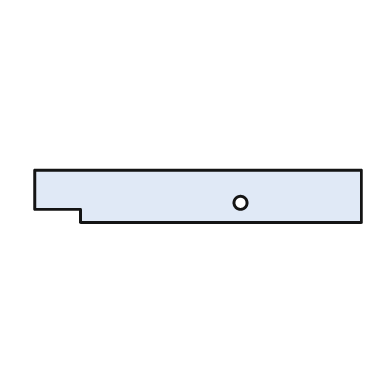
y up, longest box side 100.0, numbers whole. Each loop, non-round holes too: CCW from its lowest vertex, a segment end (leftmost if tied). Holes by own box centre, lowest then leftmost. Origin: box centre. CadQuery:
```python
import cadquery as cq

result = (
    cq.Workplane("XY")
    .moveTo(-36.0, -8.0)
    .lineTo(50.0, -8.0)
    .lineTo(50.0, 8.0)
    .lineTo(-50.0, 8.0)
    .lineTo(-50.0, -4.0)
    .lineTo(-36.0, -4.0)
    .close()
    .moveTo(13.0, -2.0)
    .circle(2.0)
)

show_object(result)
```